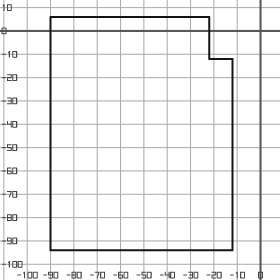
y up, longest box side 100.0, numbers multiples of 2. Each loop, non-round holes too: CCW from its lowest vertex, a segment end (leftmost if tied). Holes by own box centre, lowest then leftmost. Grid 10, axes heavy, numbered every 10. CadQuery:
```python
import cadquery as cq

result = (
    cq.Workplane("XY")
    .moveTo(-90.0, -94.0)
    .lineTo(-12.0, -94.0)
    .lineTo(-12.0, -12.0)
    .lineTo(-22.0, -12.0)
    .lineTo(-22.0, 6.0)
    .lineTo(-90.0, 6.0)
    .close()
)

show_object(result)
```